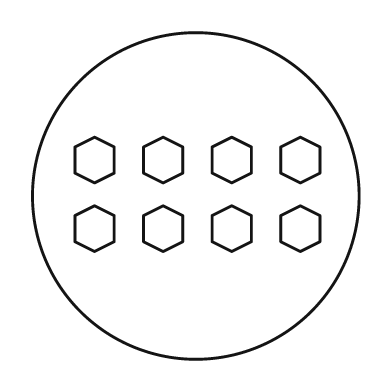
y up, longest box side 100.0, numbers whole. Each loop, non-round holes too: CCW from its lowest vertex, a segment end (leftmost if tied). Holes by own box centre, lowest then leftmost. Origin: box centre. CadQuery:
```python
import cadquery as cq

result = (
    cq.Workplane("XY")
    .moveTo(0.0, 0.0)
    .circle(50.0)
    .moveTo(-31.0, -17.0)
    .lineTo(-25.0, -14.0)
    .lineTo(-25.0, -6.0)
    .lineTo(-31.0, -3.0)
    .lineTo(-37.0, -6.0)
    .lineTo(-37.0, -14.0)
    .close()
    .moveTo(-10.0, -17.0)
    .lineTo(-4.0, -14.0)
    .lineTo(-4.0, -6.0)
    .lineTo(-10.0, -3.0)
    .lineTo(-16.0, -6.0)
    .lineTo(-16.0, -14.0)
    .close()
    .moveTo(11.0, -17.0)
    .lineTo(17.0, -14.0)
    .lineTo(17.0, -6.0)
    .lineTo(11.0, -3.0)
    .lineTo(5.0, -6.0)
    .lineTo(5.0, -14.0)
    .close()
    .moveTo(32.0, -17.0)
    .lineTo(38.0, -14.0)
    .lineTo(38.0, -6.0)
    .lineTo(32.0, -3.0)
    .lineTo(26.0, -6.0)
    .lineTo(26.0, -14.0)
    .close()
    .moveTo(-31.0, 4.0)
    .lineTo(-25.0, 7.0)
    .lineTo(-25.0, 15.0)
    .lineTo(-31.0, 18.0)
    .lineTo(-37.0, 15.0)
    .lineTo(-37.0, 7.0)
    .close()
    .moveTo(-10.0, 4.0)
    .lineTo(-4.0, 7.0)
    .lineTo(-4.0, 15.0)
    .lineTo(-10.0, 18.0)
    .lineTo(-16.0, 15.0)
    .lineTo(-16.0, 7.0)
    .close()
    .moveTo(11.0, 4.0)
    .lineTo(17.0, 7.0)
    .lineTo(17.0, 15.0)
    .lineTo(11.0, 18.0)
    .lineTo(5.0, 15.0)
    .lineTo(5.0, 7.0)
    .close()
    .moveTo(32.0, 4.0)
    .lineTo(38.0, 7.0)
    .lineTo(38.0, 15.0)
    .lineTo(32.0, 18.0)
    .lineTo(26.0, 15.0)
    .lineTo(26.0, 7.0)
    .close()
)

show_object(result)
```